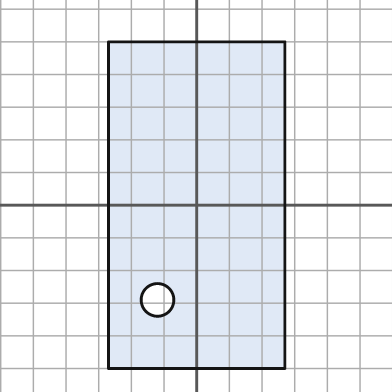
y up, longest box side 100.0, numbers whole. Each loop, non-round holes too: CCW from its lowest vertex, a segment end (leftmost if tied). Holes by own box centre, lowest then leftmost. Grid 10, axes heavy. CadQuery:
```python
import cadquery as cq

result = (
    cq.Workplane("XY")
    .moveTo(-27.0, -50.0)
    .lineTo(27.0, -50.0)
    .lineTo(27.0, 50.0)
    .lineTo(-27.0, 50.0)
    .close()
    .moveTo(-12.0, -29.0)
    .circle(5.0)
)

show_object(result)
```